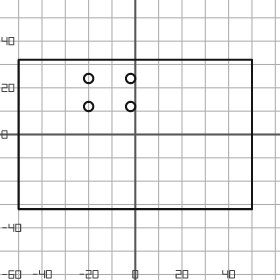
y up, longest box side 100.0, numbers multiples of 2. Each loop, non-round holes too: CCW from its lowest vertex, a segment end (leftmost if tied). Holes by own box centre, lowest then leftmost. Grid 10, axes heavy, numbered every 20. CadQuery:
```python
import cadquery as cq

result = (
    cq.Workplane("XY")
    .moveTo(-50.0, -32.0)
    .lineTo(50.0, -32.0)
    .lineTo(50.0, 32.0)
    .lineTo(-50.0, 32.0)
    .close()
    .moveTo(-20.0, 12.0)
    .circle(2.0)
    .moveTo(-2.0, 12.0)
    .circle(2.0)
    .moveTo(-20.0, 24.0)
    .circle(2.0)
    .moveTo(-2.0, 24.0)
    .circle(2.0)
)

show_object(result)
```